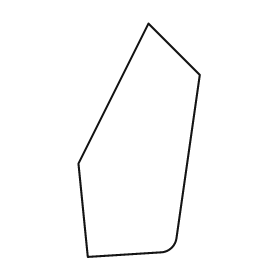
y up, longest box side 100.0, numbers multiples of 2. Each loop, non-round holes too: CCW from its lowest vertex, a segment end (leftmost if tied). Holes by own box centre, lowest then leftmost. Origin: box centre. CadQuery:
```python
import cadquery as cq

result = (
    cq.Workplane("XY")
    .moveTo(-22.0, -50.0)
    .lineTo(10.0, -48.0)
    .threePointArc((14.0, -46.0), (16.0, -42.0))
    .lineTo(26.0, 28.0)
    .lineTo(4.0, 50.0)
    .lineTo(-26.0, -10.0)
    .close()
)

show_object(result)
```